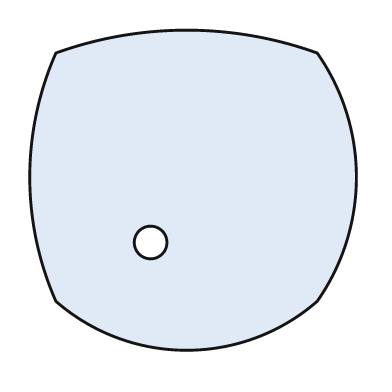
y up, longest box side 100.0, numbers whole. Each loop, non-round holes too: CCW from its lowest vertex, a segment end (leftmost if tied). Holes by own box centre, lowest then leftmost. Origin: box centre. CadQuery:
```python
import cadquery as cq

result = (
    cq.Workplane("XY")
    .moveTo(-42.0, -34.0)
    .threePointArc((-2.0, -49.0), (38.0, -34.0))
    .threePointArc((50.0, 4.0), (38.0, 42.0))
    .threePointArc((-2.0, 49.0), (-42.0, 42.0))
    .threePointArc((-50.0, 4.0), (-42.0, -34.0))
    .close()
    .moveTo(-13.0, -16.0)
    .circle(5.0)
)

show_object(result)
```